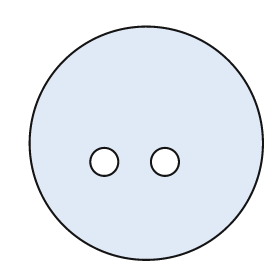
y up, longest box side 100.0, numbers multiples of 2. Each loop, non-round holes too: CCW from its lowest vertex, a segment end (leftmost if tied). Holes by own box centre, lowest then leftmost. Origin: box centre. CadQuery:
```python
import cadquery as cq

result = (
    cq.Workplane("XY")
    .moveTo(0.0, 0.0)
    .circle(50.0)
    .moveTo(-18.0, -8.0)
    .circle(6.0)
    .moveTo(8.0, -8.0)
    .circle(6.0)
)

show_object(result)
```